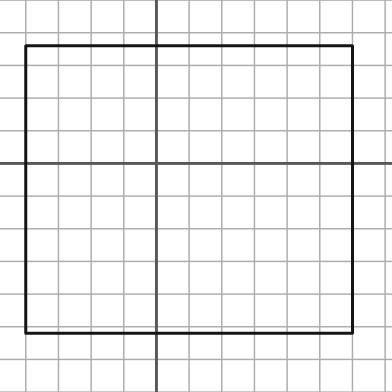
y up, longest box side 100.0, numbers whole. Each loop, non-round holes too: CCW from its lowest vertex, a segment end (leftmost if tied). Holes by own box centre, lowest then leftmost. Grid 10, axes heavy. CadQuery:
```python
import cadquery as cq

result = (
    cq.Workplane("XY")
    .moveTo(-40.0, -52.0)
    .lineTo(60.0, -52.0)
    .lineTo(60.0, 36.0)
    .lineTo(-40.0, 36.0)
    .close()
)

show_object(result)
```